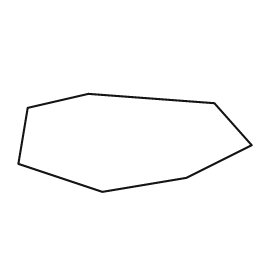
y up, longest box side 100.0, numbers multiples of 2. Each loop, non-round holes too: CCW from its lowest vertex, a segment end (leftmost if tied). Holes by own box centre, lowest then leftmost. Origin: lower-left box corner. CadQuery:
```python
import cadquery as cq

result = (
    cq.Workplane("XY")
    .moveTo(36.0, 0.0)
    .lineTo(72.0, 6.0)
    .lineTo(100.0, 20.0)
    .lineTo(84.0, 38.0)
    .lineTo(30.0, 42.0)
    .lineTo(4.0, 36.0)
    .lineTo(0.0, 12.0)
    .close()
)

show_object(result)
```